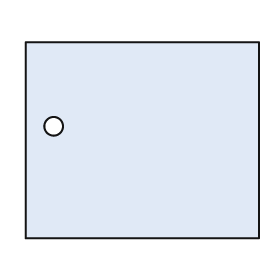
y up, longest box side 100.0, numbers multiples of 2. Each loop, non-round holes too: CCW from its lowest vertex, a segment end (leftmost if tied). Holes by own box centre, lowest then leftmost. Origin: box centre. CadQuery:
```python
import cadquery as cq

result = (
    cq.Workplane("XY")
    .moveTo(-50.0, -42.0)
    .lineTo(50.0, -42.0)
    .lineTo(50.0, 42.0)
    .lineTo(-50.0, 42.0)
    .close()
    .moveTo(-38.0, 6.0)
    .circle(4.0)
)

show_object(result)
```